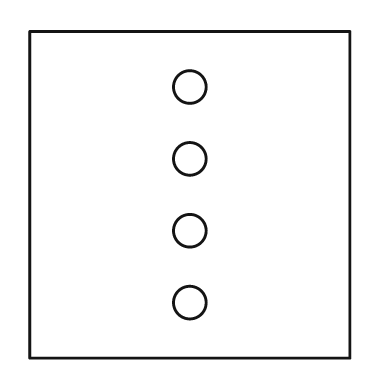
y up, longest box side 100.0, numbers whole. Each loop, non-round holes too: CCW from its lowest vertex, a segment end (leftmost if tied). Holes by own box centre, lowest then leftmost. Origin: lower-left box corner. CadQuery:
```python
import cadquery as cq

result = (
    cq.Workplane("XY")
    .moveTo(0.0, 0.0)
    .lineTo(98.0, 0.0)
    .lineTo(98.0, 100.0)
    .lineTo(0.0, 100.0)
    .close()
    .moveTo(49.0, 17.0)
    .circle(5.0)
    .moveTo(49.0, 39.0)
    .circle(5.0)
    .moveTo(49.0, 61.0)
    .circle(5.0)
    .moveTo(49.0, 83.0)
    .circle(5.0)
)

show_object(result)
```